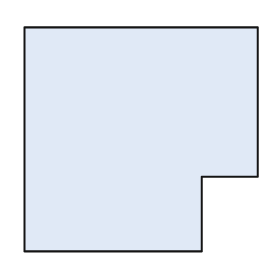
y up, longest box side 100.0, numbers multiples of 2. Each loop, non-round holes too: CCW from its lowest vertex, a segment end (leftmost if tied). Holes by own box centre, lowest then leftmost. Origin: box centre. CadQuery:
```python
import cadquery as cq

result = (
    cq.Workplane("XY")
    .moveTo(-50.0, -48.0)
    .lineTo(26.0, -48.0)
    .lineTo(26.0, -16.0)
    .lineTo(50.0, -16.0)
    .lineTo(50.0, 48.0)
    .lineTo(-50.0, 48.0)
    .close()
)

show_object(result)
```